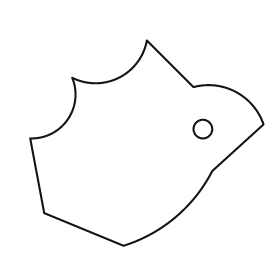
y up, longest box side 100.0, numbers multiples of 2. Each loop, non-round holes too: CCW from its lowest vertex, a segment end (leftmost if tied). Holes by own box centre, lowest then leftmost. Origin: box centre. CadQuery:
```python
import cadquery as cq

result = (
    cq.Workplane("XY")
    .moveTo(-10.0, -44.0)
    .threePointArc((12.0, -32.0), (28.0, -12.0))
    .lineTo(50.0, 8.0)
    .threePointArc((38.0, 22.0), (20.0, 24.0))
    .lineTo(0.0, 44.0)
    .threePointArc((-12.0, 28.0), (-32.0, 28.0))
    .threePointArc((-34.0, 10.0), (-50.0, 2.0))
    .lineTo(-44.0, -30.0)
    .close()
    .moveTo(24.0, 6.0)
    .circle(4.0)
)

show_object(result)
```